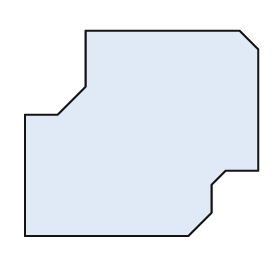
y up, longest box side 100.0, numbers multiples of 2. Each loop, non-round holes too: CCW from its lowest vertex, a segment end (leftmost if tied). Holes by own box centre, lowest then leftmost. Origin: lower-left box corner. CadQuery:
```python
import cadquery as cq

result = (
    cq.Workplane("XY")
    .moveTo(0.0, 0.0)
    .lineTo(70.0, 0.0)
    .lineTo(80.0, 10.0)
    .lineTo(80.0, 22.0)
    .lineTo(86.0, 28.0)
    .lineTo(100.0, 28.0)
    .lineTo(100.0, 80.0)
    .lineTo(92.0, 88.0)
    .lineTo(26.0, 88.0)
    .lineTo(26.0, 64.0)
    .lineTo(14.0, 52.0)
    .lineTo(0.0, 52.0)
    .close()
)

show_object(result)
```